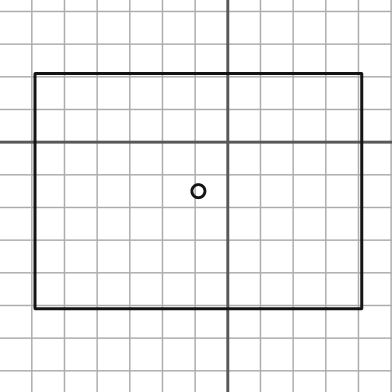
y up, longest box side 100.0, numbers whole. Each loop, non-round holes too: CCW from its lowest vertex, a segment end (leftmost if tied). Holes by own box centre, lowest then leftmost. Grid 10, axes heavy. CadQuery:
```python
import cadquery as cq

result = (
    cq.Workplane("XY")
    .moveTo(-59.0, -51.0)
    .lineTo(41.0, -51.0)
    .lineTo(41.0, 21.0)
    .lineTo(-59.0, 21.0)
    .close()
    .moveTo(-9.0, -15.0)
    .circle(2.0)
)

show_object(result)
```